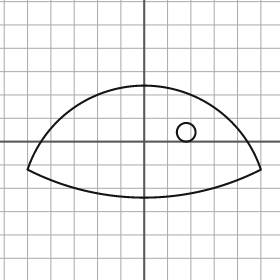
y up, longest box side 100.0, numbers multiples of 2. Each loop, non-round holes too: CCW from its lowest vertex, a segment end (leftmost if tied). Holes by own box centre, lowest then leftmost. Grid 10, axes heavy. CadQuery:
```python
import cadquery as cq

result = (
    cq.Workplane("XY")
    .moveTo(-50.0, -12.0)
    .threePointArc((0.0, -24.0), (50.0, -12.0))
    .threePointArc((0.0, 24.0), (-50.0, -12.0))
    .close()
    .moveTo(18.0, 4.0)
    .circle(4.0)
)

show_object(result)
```